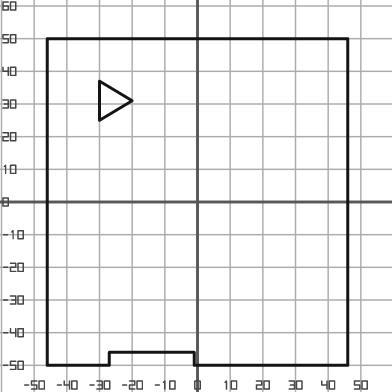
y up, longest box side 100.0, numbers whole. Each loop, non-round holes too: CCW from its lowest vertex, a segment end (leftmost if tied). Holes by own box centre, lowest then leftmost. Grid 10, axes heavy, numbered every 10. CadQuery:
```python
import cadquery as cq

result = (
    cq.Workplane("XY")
    .moveTo(-46.0, -50.0)
    .lineTo(-27.0, -50.0)
    .lineTo(-27.0, -46.0)
    .lineTo(-1.0, -46.0)
    .lineTo(-1.0, -50.0)
    .lineTo(46.0, -50.0)
    .lineTo(46.0, 50.0)
    .lineTo(-46.0, 50.0)
    .close()
    .moveTo(-30.0, 25.0)
    .lineTo(-20.0, 31.0)
    .lineTo(-30.0, 37.0)
    .close()
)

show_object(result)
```